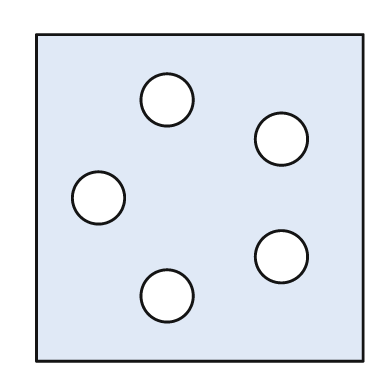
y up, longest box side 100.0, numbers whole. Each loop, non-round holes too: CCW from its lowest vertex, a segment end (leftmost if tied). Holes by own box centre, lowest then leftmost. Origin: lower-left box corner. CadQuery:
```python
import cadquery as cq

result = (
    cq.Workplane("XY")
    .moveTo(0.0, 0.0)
    .lineTo(100.0, 0.0)
    .lineTo(100.0, 100.0)
    .lineTo(0.0, 100.0)
    .close()
    .moveTo(40.0, 20.0)
    .circle(8.0)
    .moveTo(75.0, 32.0)
    .circle(8.0)
    .moveTo(19.0, 50.0)
    .circle(8.0)
    .moveTo(75.0, 68.0)
    .circle(8.0)
    .moveTo(40.0, 80.0)
    .circle(8.0)
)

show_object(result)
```